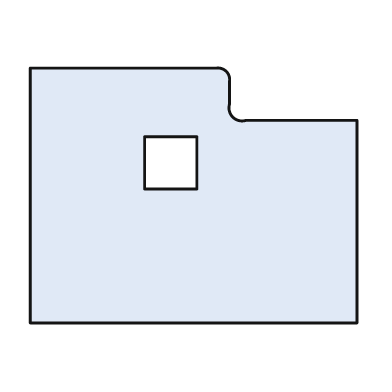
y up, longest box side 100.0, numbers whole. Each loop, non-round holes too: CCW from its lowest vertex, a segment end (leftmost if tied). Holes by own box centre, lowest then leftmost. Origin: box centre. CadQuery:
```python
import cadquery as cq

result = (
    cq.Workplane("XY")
    .moveTo(-50.0, -39.0)
    .lineTo(50.0, -39.0)
    .lineTo(50.0, 23.0)
    .lineTo(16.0, 23.0)
    .threePointArc((12.0, 24.0), (11.0, 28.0))
    .lineTo(11.0, 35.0)
    .threePointArc((10.0, 38.0), (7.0, 39.0))
    .lineTo(-50.0, 39.0)
    .close()
    .moveTo(-15.0, 2.0)
    .lineTo(1.0, 2.0)
    .lineTo(1.0, 18.0)
    .lineTo(-15.0, 18.0)
    .close()
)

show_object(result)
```